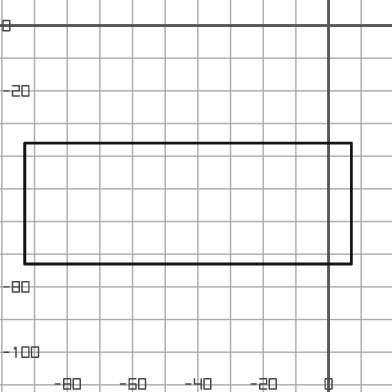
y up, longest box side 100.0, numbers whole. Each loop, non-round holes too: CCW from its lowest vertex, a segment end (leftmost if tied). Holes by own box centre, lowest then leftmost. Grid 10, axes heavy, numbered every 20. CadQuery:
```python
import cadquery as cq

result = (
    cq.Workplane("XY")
    .moveTo(-93.0, -73.0)
    .lineTo(7.0, -73.0)
    .lineTo(7.0, -36.0)
    .lineTo(-93.0, -36.0)
    .close()
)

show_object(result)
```